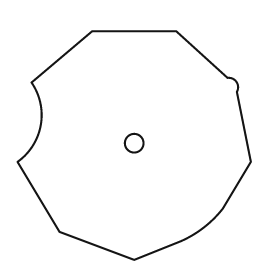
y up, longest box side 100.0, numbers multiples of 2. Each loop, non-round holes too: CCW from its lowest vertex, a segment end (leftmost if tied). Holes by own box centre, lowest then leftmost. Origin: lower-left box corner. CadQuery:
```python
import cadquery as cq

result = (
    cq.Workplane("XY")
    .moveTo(50.0, 0.0)
    .lineTo(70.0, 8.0)
    .threePointArc((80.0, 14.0), (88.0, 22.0))
    .lineTo(100.0, 42.0)
    .lineTo(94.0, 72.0)
    .threePointArc((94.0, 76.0), (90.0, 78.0))
    .lineTo(68.0, 98.0)
    .lineTo(32.0, 98.0)
    .lineTo(6.0, 76.0)
    .threePointArc((10.0, 58.0), (0.0, 42.0))
    .lineTo(18.0, 12.0)
    .close()
    .moveTo(50.0, 50.0)
    .circle(4.0)
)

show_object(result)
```